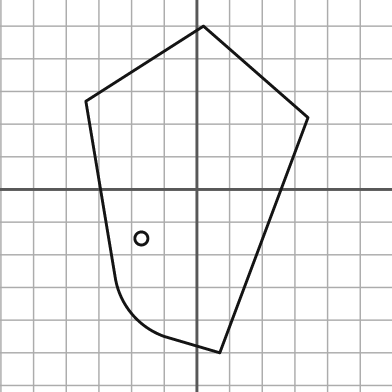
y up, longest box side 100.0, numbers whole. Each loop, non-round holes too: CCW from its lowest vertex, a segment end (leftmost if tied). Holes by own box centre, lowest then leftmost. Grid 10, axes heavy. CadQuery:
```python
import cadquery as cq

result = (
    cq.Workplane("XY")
    .moveTo(7.0, -50.0)
    .lineTo(34.0, 22.0)
    .lineTo(2.0, 50.0)
    .lineTo(-34.0, 27.0)
    .lineTo(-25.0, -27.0)
    .threePointArc((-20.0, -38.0), (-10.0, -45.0))
    .close()
    .moveTo(-17.0, -15.0)
    .circle(2.0)
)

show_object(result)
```